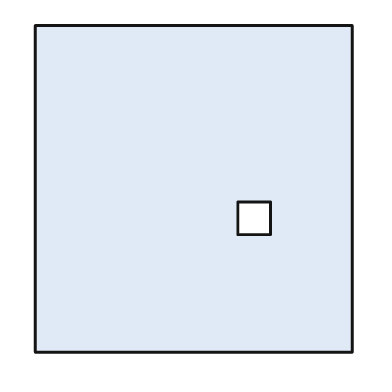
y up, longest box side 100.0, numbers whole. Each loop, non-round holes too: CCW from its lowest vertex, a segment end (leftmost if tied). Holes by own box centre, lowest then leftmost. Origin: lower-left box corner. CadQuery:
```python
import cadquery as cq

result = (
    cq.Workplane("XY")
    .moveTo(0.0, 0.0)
    .lineTo(97.0, 0.0)
    .lineTo(97.0, 100.0)
    .lineTo(0.0, 100.0)
    .close()
    .moveTo(62.0, 36.0)
    .lineTo(72.0, 36.0)
    .lineTo(72.0, 46.0)
    .lineTo(62.0, 46.0)
    .close()
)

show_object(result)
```